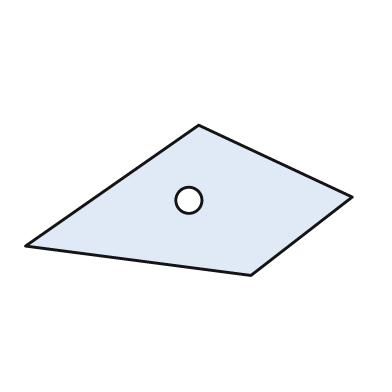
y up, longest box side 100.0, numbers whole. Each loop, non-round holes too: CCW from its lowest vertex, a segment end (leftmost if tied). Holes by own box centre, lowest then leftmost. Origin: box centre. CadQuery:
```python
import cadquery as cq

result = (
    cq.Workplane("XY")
    .moveTo(19.0, -23.0)
    .lineTo(50.0, 1.0)
    .lineTo(3.0, 23.0)
    .lineTo(-50.0, -14.0)
    .close()
    .moveTo(0.0, 0.0)
    .circle(4.0)
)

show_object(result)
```